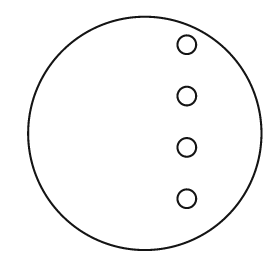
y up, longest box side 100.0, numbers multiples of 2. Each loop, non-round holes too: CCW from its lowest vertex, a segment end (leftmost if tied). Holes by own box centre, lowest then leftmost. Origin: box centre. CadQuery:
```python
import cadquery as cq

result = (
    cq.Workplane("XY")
    .moveTo(0.0, 0.0)
    .circle(50.0)
    .moveTo(18.0, -28.0)
    .circle(4.0)
    .moveTo(18.0, -6.0)
    .circle(4.0)
    .moveTo(18.0, 16.0)
    .circle(4.0)
    .moveTo(18.0, 38.0)
    .circle(4.0)
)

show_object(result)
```